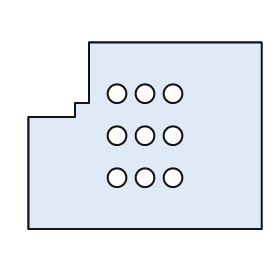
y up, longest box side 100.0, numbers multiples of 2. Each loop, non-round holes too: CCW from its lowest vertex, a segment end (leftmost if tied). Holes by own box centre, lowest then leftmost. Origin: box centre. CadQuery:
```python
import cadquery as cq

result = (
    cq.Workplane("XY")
    .moveTo(-50.0, -40.0)
    .lineTo(50.0, -40.0)
    .lineTo(50.0, 40.0)
    .lineTo(-24.0, 40.0)
    .lineTo(-24.0, 14.0)
    .lineTo(-30.0, 14.0)
    .lineTo(-30.0, 8.0)
    .lineTo(-50.0, 8.0)
    .close()
    .moveTo(-12.0, -18.0)
    .circle(4.0)
    .moveTo(0.0, -18.0)
    .circle(4.0)
    .moveTo(12.0, -18.0)
    .circle(4.0)
    .moveTo(-12.0, 0.0)
    .circle(4.0)
    .moveTo(0.0, 0.0)
    .circle(4.0)
    .moveTo(12.0, 0.0)
    .circle(4.0)
    .moveTo(-12.0, 18.0)
    .circle(4.0)
    .moveTo(0.0, 18.0)
    .circle(4.0)
    .moveTo(12.0, 18.0)
    .circle(4.0)
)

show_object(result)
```